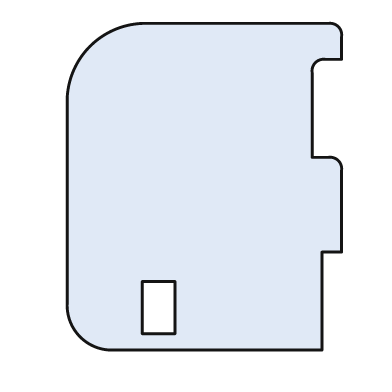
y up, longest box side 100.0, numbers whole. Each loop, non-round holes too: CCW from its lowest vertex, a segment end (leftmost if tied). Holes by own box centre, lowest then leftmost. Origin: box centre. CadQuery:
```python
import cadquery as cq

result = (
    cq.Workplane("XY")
    .moveTo(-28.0, -50.0)
    .lineTo(36.0, -50.0)
    .lineTo(36.0, -20.0)
    .lineTo(42.0, -20.0)
    .lineTo(42.0, 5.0)
    .threePointArc((41.0, 8.0), (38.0, 9.0))
    .lineTo(33.0, 9.0)
    .lineTo(33.0, 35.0)
    .threePointArc((34.0, 38.0), (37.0, 39.0))
    .lineTo(42.0, 39.0)
    .lineTo(42.0, 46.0)
    .threePointArc((41.0, 49.0), (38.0, 50.0))
    .lineTo(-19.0, 50.0)
    .threePointArc((-35.0, 43.0), (-42.0, 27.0))
    .lineTo(-42.0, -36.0)
    .threePointArc((-38.0, -46.0), (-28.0, -50.0))
    .close()
    .moveTo(-19.0, -45.0)
    .lineTo(-9.0, -45.0)
    .lineTo(-9.0, -29.0)
    .lineTo(-19.0, -29.0)
    .close()
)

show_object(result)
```